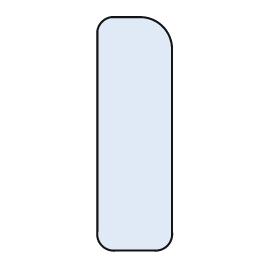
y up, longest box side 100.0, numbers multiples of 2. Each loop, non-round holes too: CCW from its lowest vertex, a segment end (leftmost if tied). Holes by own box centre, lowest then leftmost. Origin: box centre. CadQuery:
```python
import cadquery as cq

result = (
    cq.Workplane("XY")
    .moveTo(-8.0, -50.0)
    .lineTo(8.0, -50.0)
    .threePointArc((14.0, -48.0), (16.0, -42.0))
    .lineTo(16.0, 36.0)
    .threePointArc((12.0, 46.0), (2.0, 50.0))
    .lineTo(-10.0, 50.0)
    .threePointArc((-14.0, 48.0), (-16.0, 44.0))
    .lineTo(-16.0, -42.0)
    .threePointArc((-14.0, -48.0), (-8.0, -50.0))
    .close()
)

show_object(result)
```